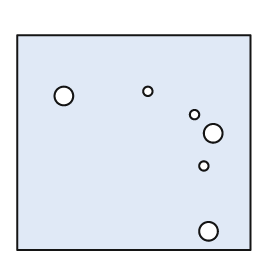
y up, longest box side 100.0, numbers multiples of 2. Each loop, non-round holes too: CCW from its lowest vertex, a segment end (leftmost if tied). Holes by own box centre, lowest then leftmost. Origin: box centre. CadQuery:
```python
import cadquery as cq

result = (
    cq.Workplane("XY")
    .moveTo(-50.0, -46.0)
    .lineTo(50.0, -46.0)
    .lineTo(50.0, 46.0)
    .lineTo(-50.0, 46.0)
    .close()
    .moveTo(32.0, -38.0)
    .circle(4.0)
    .moveTo(30.0, -10.0)
    .circle(2.0)
    .moveTo(34.0, 4.0)
    .circle(4.0)
    .moveTo(26.0, 12.0)
    .circle(2.0)
    .moveTo(-30.0, 20.0)
    .circle(4.0)
    .moveTo(6.0, 22.0)
    .circle(2.0)
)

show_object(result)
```